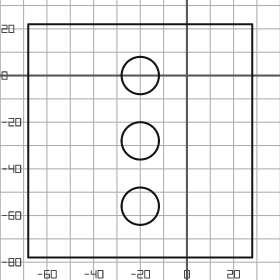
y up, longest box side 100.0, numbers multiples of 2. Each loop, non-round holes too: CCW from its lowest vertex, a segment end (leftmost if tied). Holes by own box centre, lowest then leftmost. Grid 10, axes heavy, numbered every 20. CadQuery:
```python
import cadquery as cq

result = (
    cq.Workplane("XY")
    .moveTo(-68.0, -78.0)
    .lineTo(28.0, -78.0)
    .lineTo(28.0, 22.0)
    .lineTo(-68.0, 22.0)
    .close()
    .moveTo(-20.0, -56.0)
    .circle(8.0)
    .moveTo(-20.0, -28.0)
    .circle(8.0)
    .moveTo(-20.0, 0.0)
    .circle(8.0)
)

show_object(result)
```